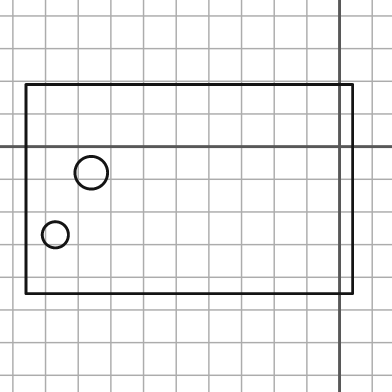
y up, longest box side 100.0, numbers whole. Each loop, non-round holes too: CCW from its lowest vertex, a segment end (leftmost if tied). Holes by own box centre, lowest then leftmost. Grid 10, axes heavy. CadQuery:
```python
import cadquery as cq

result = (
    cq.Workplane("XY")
    .moveTo(-96.0, -45.0)
    .lineTo(4.0, -45.0)
    .lineTo(4.0, 19.0)
    .lineTo(-96.0, 19.0)
    .close()
    .moveTo(-87.0, -27.0)
    .circle(4.0)
    .moveTo(-76.0, -8.0)
    .circle(5.0)
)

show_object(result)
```